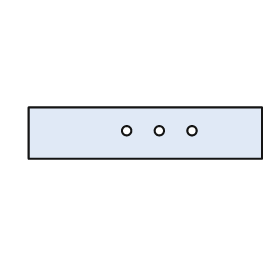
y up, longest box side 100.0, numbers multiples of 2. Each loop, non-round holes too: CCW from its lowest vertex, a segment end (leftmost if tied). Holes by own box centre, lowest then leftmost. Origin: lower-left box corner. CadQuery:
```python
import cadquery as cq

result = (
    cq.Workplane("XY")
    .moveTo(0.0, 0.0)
    .lineTo(100.0, 0.0)
    .lineTo(100.0, 22.0)
    .lineTo(0.0, 22.0)
    .close()
    .moveTo(42.0, 12.0)
    .circle(2.0)
    .moveTo(56.0, 12.0)
    .circle(2.0)
    .moveTo(70.0, 12.0)
    .circle(2.0)
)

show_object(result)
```